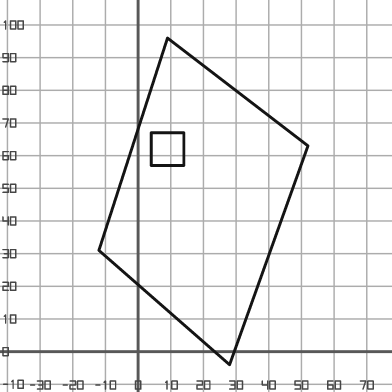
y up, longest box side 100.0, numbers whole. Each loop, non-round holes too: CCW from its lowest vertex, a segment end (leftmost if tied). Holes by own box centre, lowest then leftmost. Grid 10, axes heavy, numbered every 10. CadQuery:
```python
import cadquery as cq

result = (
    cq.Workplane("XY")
    .moveTo(28.0, -4.0)
    .lineTo(52.0, 63.0)
    .lineTo(9.0, 96.0)
    .lineTo(-12.0, 31.0)
    .close()
    .moveTo(4.0, 57.0)
    .lineTo(14.0, 57.0)
    .lineTo(14.0, 67.0)
    .lineTo(4.0, 67.0)
    .close()
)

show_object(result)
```